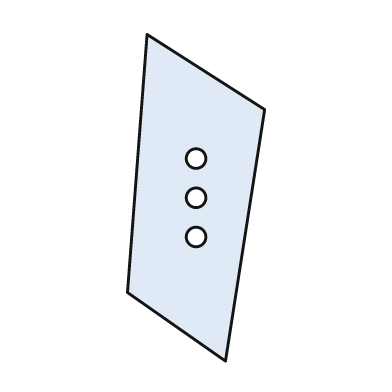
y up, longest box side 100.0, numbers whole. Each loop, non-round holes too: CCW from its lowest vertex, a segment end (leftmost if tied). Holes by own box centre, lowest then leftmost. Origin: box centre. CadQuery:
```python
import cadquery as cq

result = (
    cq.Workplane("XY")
    .moveTo(9.0, -50.0)
    .lineTo(21.0, 27.0)
    .lineTo(-15.0, 50.0)
    .lineTo(-21.0, -29.0)
    .close()
    .moveTo(0.0, -12.0)
    .circle(3.0)
    .moveTo(0.0, 0.0)
    .circle(3.0)
    .moveTo(0.0, 12.0)
    .circle(3.0)
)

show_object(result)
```